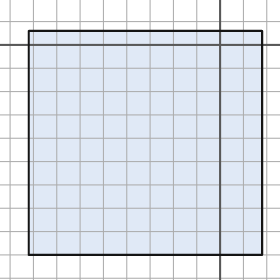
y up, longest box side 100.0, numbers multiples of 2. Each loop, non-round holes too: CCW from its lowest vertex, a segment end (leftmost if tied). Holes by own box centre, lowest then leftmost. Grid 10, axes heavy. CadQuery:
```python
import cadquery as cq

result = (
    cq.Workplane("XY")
    .moveTo(-82.0, -90.0)
    .lineTo(18.0, -90.0)
    .lineTo(18.0, 6.0)
    .lineTo(-82.0, 6.0)
    .close()
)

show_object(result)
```